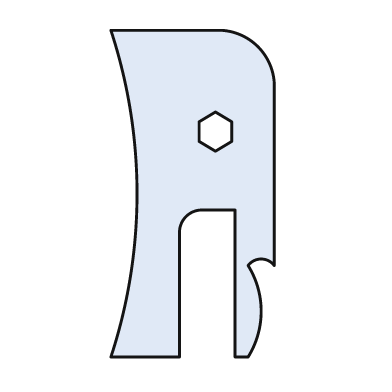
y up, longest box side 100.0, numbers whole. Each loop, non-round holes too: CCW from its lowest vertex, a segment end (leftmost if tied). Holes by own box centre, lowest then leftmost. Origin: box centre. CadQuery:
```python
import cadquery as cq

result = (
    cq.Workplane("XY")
    .moveTo(-25.0, -50.0)
    .lineTo(-4.0, -50.0)
    .lineTo(-4.0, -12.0)
    .threePointArc((-2.0, -7.0), (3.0, -5.0))
    .lineTo(13.0, -5.0)
    .lineTo(13.0, -50.0)
    .lineTo(17.0, -50.0)
    .threePointArc((21.0, -36.0), (17.0, -22.0))
    .threePointArc((21.0, -20.0), (25.0, -22.0))
    .lineTo(25.0, 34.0)
    .threePointArc((20.0, 45.0), (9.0, 50.0))
    .lineTo(-25.0, 50.0)
    .threePointArc((-17.0, 0.0), (-25.0, -50.0))
    .close()
    .moveTo(7.0, 13.0)
    .lineTo(12.0, 16.0)
    .lineTo(12.0, 22.0)
    .lineTo(7.0, 25.0)
    .lineTo(2.0, 22.0)
    .lineTo(2.0, 16.0)
    .close()
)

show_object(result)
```